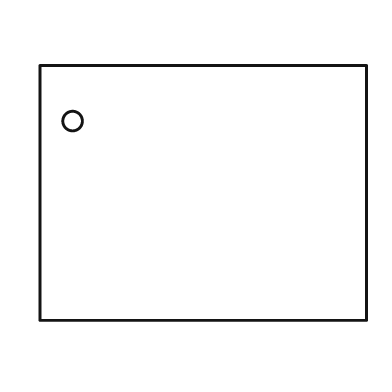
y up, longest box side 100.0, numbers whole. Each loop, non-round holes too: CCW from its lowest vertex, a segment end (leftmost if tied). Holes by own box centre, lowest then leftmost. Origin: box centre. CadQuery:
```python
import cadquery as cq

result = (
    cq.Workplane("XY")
    .moveTo(-50.0, -39.0)
    .lineTo(50.0, -39.0)
    .lineTo(50.0, 39.0)
    .lineTo(-50.0, 39.0)
    .close()
    .moveTo(-40.0, 22.0)
    .circle(3.0)
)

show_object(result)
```